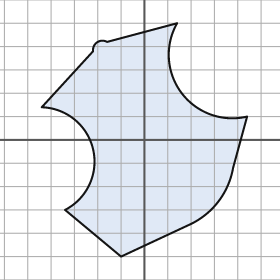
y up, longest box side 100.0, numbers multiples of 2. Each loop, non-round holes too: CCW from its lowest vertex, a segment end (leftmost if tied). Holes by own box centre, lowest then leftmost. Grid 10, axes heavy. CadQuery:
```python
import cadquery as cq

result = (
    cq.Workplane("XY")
    .moveTo(-10.0, -50.0)
    .lineTo(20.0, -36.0)
    .threePointArc((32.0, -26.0), (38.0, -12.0))
    .lineTo(44.0, 10.0)
    .threePointArc((16.0, 20.0), (14.0, 50.0))
    .lineTo(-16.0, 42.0)
    .threePointArc((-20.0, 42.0), (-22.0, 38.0))
    .lineTo(-44.0, 14.0)
    .threePointArc((-22.0, -4.0), (-34.0, -30.0))
    .close()
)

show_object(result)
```